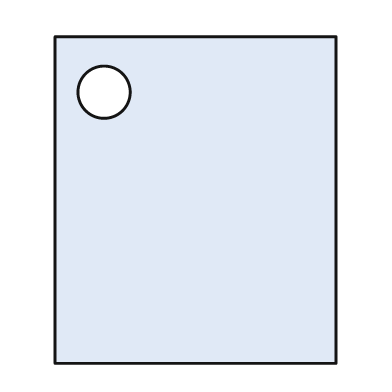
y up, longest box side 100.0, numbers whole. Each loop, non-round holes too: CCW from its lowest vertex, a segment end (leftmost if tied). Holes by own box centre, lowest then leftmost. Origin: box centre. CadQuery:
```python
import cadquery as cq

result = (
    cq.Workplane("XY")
    .moveTo(-43.0, -50.0)
    .lineTo(43.0, -50.0)
    .lineTo(43.0, 50.0)
    .lineTo(-43.0, 50.0)
    .close()
    .moveTo(-28.0, 33.0)
    .circle(8.0)
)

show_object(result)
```